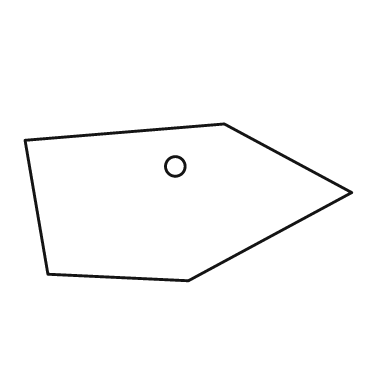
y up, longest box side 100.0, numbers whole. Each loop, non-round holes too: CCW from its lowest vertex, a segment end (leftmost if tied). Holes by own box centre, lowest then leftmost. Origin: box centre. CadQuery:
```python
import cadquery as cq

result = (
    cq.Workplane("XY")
    .moveTo(0.0, -24.0)
    .lineTo(50.0, 3.0)
    .lineTo(11.0, 24.0)
    .lineTo(-50.0, 19.0)
    .lineTo(-43.0, -22.0)
    .close()
    .moveTo(-4.0, 11.0)
    .circle(3.0)
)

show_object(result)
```